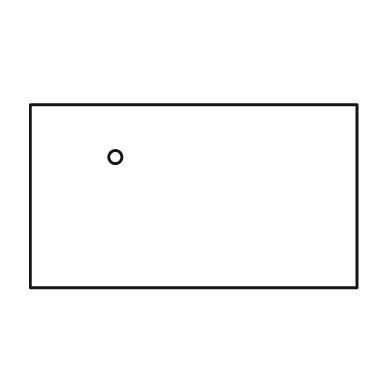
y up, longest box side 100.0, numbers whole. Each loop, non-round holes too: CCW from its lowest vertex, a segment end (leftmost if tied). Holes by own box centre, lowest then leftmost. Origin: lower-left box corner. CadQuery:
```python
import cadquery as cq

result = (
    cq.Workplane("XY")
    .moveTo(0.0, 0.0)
    .lineTo(100.0, 0.0)
    .lineTo(100.0, 56.0)
    .lineTo(0.0, 56.0)
    .close()
    .moveTo(26.0, 40.0)
    .circle(2.0)
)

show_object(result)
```